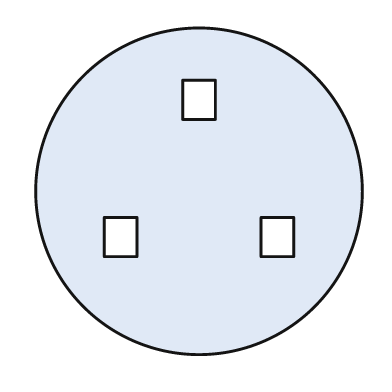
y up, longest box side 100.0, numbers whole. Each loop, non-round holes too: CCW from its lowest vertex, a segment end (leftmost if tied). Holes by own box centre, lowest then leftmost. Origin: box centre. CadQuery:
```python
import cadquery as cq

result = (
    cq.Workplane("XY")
    .moveTo(0.0, 0.0)
    .circle(50.0)
    .moveTo(-29.0, -20.0)
    .lineTo(-19.0, -20.0)
    .lineTo(-19.0, -8.0)
    .lineTo(-29.0, -8.0)
    .close()
    .moveTo(19.0, -20.0)
    .lineTo(29.0, -20.0)
    .lineTo(29.0, -8.0)
    .lineTo(19.0, -8.0)
    .close()
    .moveTo(-5.0, 22.0)
    .lineTo(5.0, 22.0)
    .lineTo(5.0, 34.0)
    .lineTo(-5.0, 34.0)
    .close()
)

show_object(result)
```